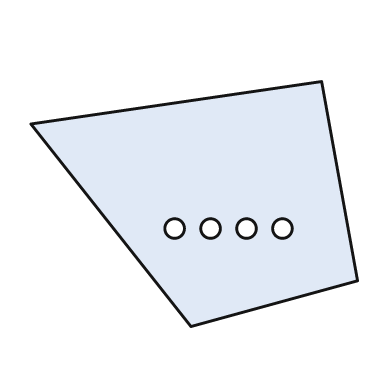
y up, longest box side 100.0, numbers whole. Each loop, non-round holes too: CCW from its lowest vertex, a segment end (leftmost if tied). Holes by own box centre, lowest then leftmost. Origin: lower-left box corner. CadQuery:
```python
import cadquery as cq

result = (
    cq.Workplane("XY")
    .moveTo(49.0, 0.0)
    .lineTo(100.0, 14.0)
    .lineTo(89.0, 75.0)
    .lineTo(0.0, 62.0)
    .close()
    .moveTo(44.0, 30.0)
    .circle(3.0)
    .moveTo(55.0, 30.0)
    .circle(3.0)
    .moveTo(66.0, 30.0)
    .circle(3.0)
    .moveTo(77.0, 30.0)
    .circle(3.0)
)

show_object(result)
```